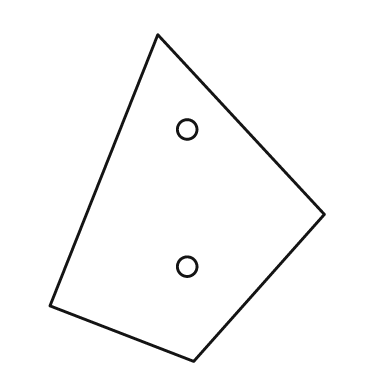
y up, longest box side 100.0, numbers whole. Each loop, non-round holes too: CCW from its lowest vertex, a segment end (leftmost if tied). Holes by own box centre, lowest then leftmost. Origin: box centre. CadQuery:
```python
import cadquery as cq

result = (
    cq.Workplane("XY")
    .moveTo(2.0, -50.0)
    .lineTo(42.0, -5.0)
    .lineTo(-9.0, 50.0)
    .lineTo(-42.0, -33.0)
    .close()
    .moveTo(0.0, -21.0)
    .circle(3.0)
    .moveTo(0.0, 21.0)
    .circle(3.0)
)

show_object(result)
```